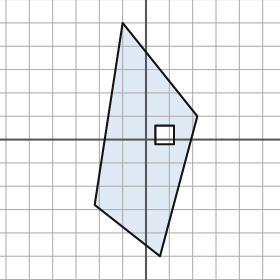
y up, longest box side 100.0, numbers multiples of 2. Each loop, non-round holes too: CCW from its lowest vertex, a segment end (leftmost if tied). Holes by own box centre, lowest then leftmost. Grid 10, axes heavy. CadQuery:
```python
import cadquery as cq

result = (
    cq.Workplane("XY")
    .moveTo(6.0, -50.0)
    .lineTo(22.0, 10.0)
    .lineTo(-10.0, 50.0)
    .lineTo(-22.0, -28.0)
    .close()
    .moveTo(4.0, -2.0)
    .lineTo(12.0, -2.0)
    .lineTo(12.0, 6.0)
    .lineTo(4.0, 6.0)
    .close()
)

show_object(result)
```